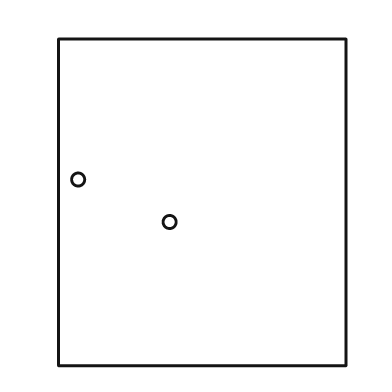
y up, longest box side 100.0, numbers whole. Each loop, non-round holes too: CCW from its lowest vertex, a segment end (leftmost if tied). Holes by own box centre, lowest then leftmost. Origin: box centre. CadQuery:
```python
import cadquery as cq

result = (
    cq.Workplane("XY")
    .moveTo(-44.0, -50.0)
    .lineTo(44.0, -50.0)
    .lineTo(44.0, 50.0)
    .lineTo(-44.0, 50.0)
    .close()
    .moveTo(-10.0, -6.0)
    .circle(2.0)
    .moveTo(-38.0, 7.0)
    .circle(2.0)
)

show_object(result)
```